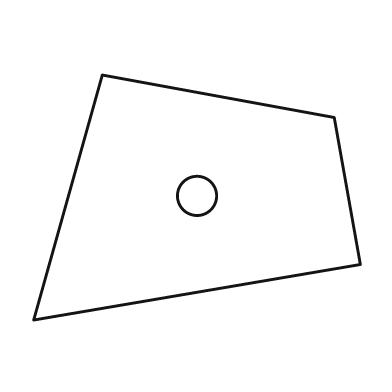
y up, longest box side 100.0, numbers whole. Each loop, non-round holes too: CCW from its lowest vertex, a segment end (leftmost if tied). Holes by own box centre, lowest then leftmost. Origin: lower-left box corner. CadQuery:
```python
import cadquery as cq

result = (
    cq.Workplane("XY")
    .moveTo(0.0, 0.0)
    .lineTo(100.0, 17.0)
    .lineTo(92.0, 62.0)
    .lineTo(21.0, 75.0)
    .close()
    .moveTo(50.0, 38.0)
    .circle(6.0)
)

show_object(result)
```